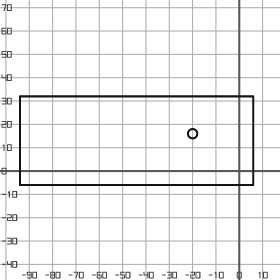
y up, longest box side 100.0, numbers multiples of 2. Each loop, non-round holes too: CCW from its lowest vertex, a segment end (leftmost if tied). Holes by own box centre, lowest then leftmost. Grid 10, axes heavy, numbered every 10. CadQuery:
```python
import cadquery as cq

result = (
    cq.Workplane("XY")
    .moveTo(-94.0, -6.0)
    .lineTo(6.0, -6.0)
    .lineTo(6.0, 32.0)
    .lineTo(-94.0, 32.0)
    .close()
    .moveTo(-20.0, 16.0)
    .circle(2.0)
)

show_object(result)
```